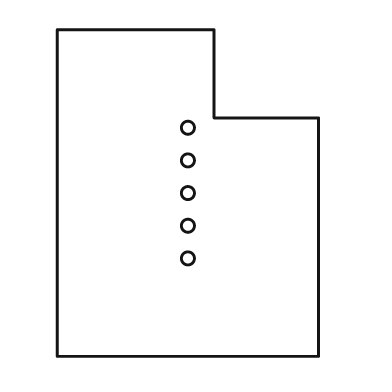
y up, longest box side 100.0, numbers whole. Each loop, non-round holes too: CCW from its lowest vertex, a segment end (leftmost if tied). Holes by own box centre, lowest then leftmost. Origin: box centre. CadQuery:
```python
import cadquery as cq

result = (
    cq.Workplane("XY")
    .moveTo(-40.0, -50.0)
    .lineTo(40.0, -50.0)
    .lineTo(40.0, 23.0)
    .lineTo(8.0, 23.0)
    .lineTo(8.0, 50.0)
    .lineTo(-40.0, 50.0)
    .close()
    .moveTo(0.0, -20.0)
    .circle(2.0)
    .moveTo(0.0, -10.0)
    .circle(2.0)
    .moveTo(0.0, 0.0)
    .circle(2.0)
    .moveTo(0.0, 10.0)
    .circle(2.0)
    .moveTo(0.0, 20.0)
    .circle(2.0)
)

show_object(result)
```